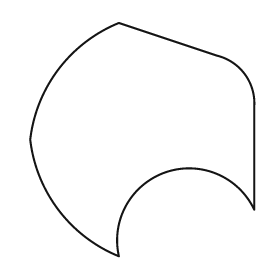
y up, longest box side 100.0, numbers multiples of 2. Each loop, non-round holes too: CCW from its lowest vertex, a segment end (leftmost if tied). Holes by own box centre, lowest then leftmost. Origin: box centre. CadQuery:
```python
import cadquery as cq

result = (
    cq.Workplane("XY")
    .moveTo(-10.0, -50.0)
    .threePointArc((10.0, -14.0), (48.0, -30.0))
    .lineTo(48.0, 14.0)
    .threePointArc((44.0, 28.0), (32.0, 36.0))
    .lineTo(-10.0, 50.0)
    .threePointArc((-36.0, 30.0), (-48.0, 0.0))
    .threePointArc((-36.0, -30.0), (-10.0, -50.0))
    .close()
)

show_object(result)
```